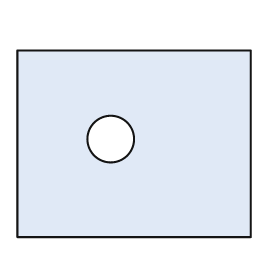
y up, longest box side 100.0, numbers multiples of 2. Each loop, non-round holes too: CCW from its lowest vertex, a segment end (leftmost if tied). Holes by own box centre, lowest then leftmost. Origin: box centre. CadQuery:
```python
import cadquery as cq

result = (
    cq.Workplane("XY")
    .moveTo(-50.0, -40.0)
    .lineTo(50.0, -40.0)
    .lineTo(50.0, 40.0)
    .lineTo(-50.0, 40.0)
    .close()
    .moveTo(-10.0, 2.0)
    .circle(10.0)
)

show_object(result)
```